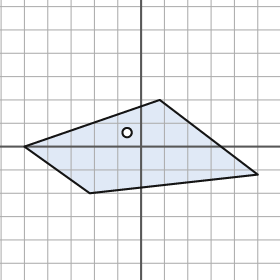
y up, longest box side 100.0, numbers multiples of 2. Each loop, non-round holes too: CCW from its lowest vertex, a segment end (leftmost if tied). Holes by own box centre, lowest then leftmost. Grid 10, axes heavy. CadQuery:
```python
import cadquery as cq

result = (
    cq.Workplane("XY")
    .moveTo(-22.0, -20.0)
    .lineTo(50.0, -12.0)
    .lineTo(8.0, 20.0)
    .lineTo(-50.0, 0.0)
    .close()
    .moveTo(-6.0, 6.0)
    .circle(2.0)
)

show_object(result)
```